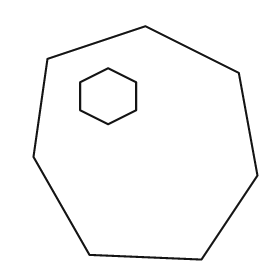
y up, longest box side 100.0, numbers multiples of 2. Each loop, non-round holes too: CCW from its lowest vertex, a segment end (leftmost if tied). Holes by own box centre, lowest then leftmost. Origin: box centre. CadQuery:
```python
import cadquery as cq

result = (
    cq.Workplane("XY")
    .moveTo(24.0, -50.0)
    .lineTo(48.0, -14.0)
    .lineTo(40.0, 30.0)
    .lineTo(0.0, 50.0)
    .lineTo(-42.0, 36.0)
    .lineTo(-48.0, -6.0)
    .lineTo(-24.0, -48.0)
    .close()
    .moveTo(-16.0, 8.0)
    .lineTo(-4.0, 14.0)
    .lineTo(-4.0, 26.0)
    .lineTo(-16.0, 32.0)
    .lineTo(-28.0, 26.0)
    .lineTo(-28.0, 14.0)
    .close()
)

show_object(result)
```